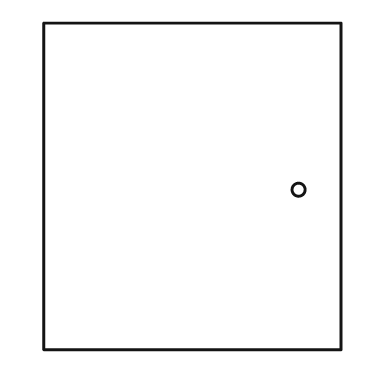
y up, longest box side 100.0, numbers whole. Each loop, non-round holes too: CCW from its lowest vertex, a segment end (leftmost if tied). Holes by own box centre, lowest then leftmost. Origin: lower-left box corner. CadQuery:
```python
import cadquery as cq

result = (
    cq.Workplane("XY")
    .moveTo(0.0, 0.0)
    .lineTo(91.0, 0.0)
    .lineTo(91.0, 100.0)
    .lineTo(0.0, 100.0)
    .close()
    .moveTo(78.0, 49.0)
    .circle(2.0)
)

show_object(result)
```